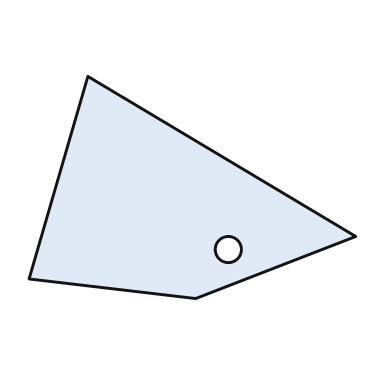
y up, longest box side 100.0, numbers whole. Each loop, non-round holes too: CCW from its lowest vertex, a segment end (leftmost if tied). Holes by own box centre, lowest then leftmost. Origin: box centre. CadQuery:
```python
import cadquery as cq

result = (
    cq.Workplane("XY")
    .moveTo(1.0, -34.0)
    .lineTo(50.0, -15.0)
    .lineTo(-32.0, 34.0)
    .lineTo(-50.0, -28.0)
    .close()
    .moveTo(11.0, -19.0)
    .circle(4.0)
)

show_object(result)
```